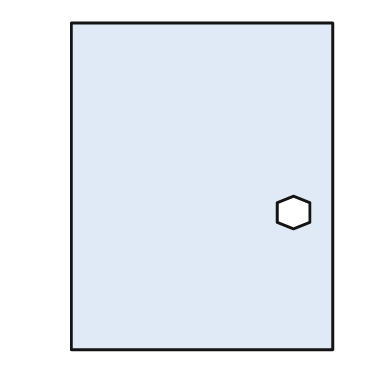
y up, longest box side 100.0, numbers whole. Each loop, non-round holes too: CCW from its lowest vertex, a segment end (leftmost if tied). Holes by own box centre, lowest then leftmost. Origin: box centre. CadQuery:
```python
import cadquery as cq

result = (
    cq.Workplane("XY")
    .moveTo(-40.0, -50.0)
    .lineTo(40.0, -50.0)
    .lineTo(40.0, 50.0)
    .lineTo(-40.0, 50.0)
    .close()
    .moveTo(28.0, -13.0)
    .lineTo(33.0, -11.0)
    .lineTo(33.0, -5.0)
    .lineTo(28.0, -3.0)
    .lineTo(23.0, -5.0)
    .lineTo(23.0, -11.0)
    .close()
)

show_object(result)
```